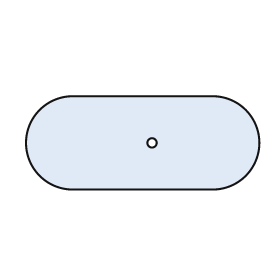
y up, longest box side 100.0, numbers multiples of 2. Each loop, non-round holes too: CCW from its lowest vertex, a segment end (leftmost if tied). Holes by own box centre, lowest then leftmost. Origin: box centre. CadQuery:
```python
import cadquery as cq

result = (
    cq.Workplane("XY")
    .moveTo(-30.0, -20.0)
    .lineTo(30.0, -20.0)
    .threePointArc((50.0, 0.0), (30.0, 20.0))
    .lineTo(-30.0, 20.0)
    .threePointArc((-50.0, 0.0), (-30.0, -20.0))
    .close()
    .moveTo(4.0, 0.0)
    .circle(2.0)
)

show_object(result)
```